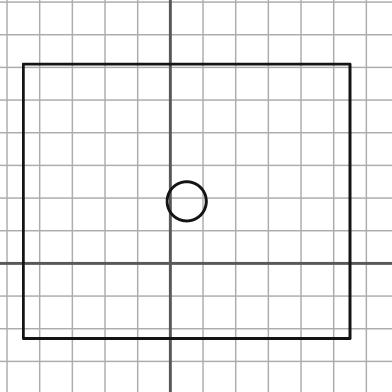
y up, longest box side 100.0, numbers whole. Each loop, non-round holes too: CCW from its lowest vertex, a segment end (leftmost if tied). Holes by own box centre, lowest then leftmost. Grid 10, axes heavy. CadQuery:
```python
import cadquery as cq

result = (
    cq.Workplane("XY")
    .moveTo(-45.0, -23.0)
    .lineTo(55.0, -23.0)
    .lineTo(55.0, 61.0)
    .lineTo(-45.0, 61.0)
    .close()
    .moveTo(5.0, 19.0)
    .circle(6.0)
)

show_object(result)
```